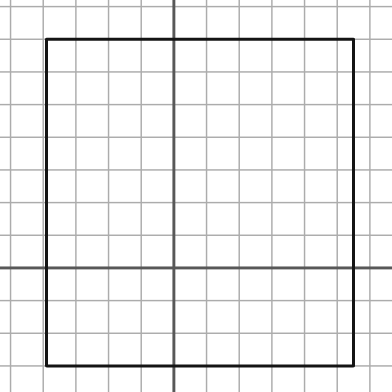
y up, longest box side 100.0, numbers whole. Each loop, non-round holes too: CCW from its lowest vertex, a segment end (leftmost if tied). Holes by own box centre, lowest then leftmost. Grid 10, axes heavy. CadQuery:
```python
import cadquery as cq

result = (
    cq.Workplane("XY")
    .moveTo(-39.0, -30.0)
    .lineTo(55.0, -30.0)
    .lineTo(55.0, 70.0)
    .lineTo(-39.0, 70.0)
    .close()
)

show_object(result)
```